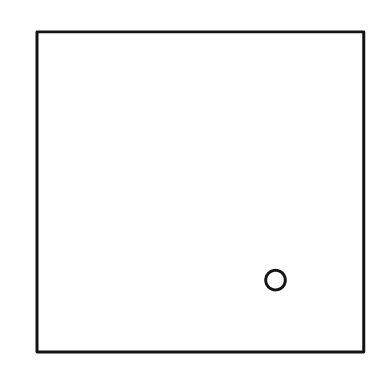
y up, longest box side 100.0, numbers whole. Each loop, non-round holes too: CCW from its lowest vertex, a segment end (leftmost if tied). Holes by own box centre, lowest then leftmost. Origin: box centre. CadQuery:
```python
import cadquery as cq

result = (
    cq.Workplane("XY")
    .moveTo(-50.0, -49.0)
    .lineTo(50.0, -49.0)
    .lineTo(50.0, 49.0)
    .lineTo(-50.0, 49.0)
    .close()
    .moveTo(23.0, -27.0)
    .circle(3.0)
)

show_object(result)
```